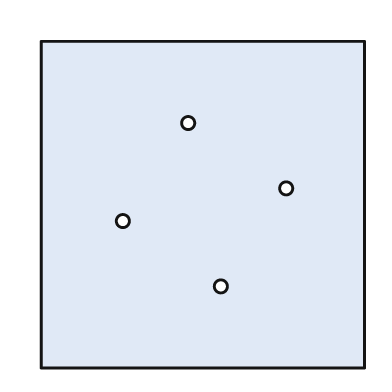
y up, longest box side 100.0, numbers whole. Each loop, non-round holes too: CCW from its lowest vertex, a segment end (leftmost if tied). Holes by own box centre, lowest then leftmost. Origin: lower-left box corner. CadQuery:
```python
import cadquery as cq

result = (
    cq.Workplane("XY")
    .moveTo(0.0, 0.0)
    .lineTo(99.0, 0.0)
    .lineTo(99.0, 100.0)
    .lineTo(0.0, 100.0)
    .close()
    .moveTo(55.0, 25.0)
    .circle(2.0)
    .moveTo(25.0, 45.0)
    .circle(2.0)
    .moveTo(75.0, 55.0)
    .circle(2.0)
    .moveTo(45.0, 75.0)
    .circle(2.0)
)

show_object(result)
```